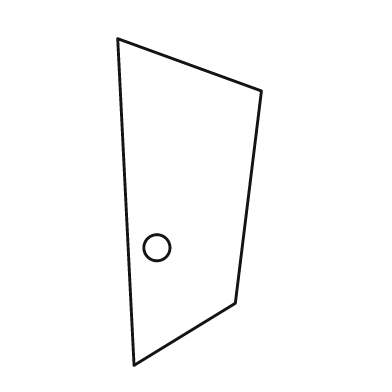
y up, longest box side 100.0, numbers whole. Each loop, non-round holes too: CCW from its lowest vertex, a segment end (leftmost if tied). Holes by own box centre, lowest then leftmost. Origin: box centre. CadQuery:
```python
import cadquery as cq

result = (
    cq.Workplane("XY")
    .moveTo(-17.0, -50.0)
    .lineTo(14.0, -31.0)
    .lineTo(22.0, 34.0)
    .lineTo(-22.0, 50.0)
    .close()
    .moveTo(-10.0, -14.0)
    .circle(4.0)
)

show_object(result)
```